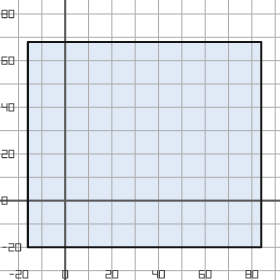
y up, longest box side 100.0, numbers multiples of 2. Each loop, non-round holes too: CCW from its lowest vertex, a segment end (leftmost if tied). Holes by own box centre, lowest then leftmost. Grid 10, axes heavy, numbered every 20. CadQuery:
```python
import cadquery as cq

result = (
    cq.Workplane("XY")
    .moveTo(-16.0, -20.0)
    .lineTo(84.0, -20.0)
    .lineTo(84.0, 68.0)
    .lineTo(-16.0, 68.0)
    .close()
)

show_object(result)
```